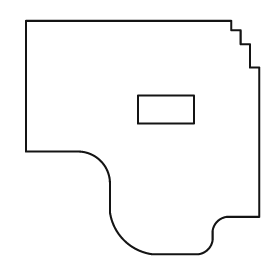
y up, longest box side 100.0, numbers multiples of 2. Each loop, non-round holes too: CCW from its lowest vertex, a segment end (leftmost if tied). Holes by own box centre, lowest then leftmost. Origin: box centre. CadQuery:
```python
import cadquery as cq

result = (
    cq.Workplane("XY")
    .moveTo(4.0, -50.0)
    .lineTo(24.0, -50.0)
    .threePointArc((28.0, -48.0), (30.0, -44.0))
    .lineTo(30.0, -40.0)
    .threePointArc((32.0, -36.0), (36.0, -34.0))
    .lineTo(50.0, -34.0)
    .lineTo(50.0, 30.0)
    .lineTo(46.0, 30.0)
    .lineTo(46.0, 40.0)
    .lineTo(42.0, 40.0)
    .lineTo(42.0, 46.0)
    .lineTo(38.0, 46.0)
    .lineTo(38.0, 50.0)
    .lineTo(-50.0, 50.0)
    .lineTo(-50.0, -6.0)
    .lineTo(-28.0, -6.0)
    .threePointArc((-18.0, -10.0), (-14.0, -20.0))
    .lineTo(-14.0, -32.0)
    .threePointArc((-8.0, -44.0), (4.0, -50.0))
    .close()
    .moveTo(-2.0, 6.0)
    .lineTo(22.0, 6.0)
    .lineTo(22.0, 18.0)
    .lineTo(-2.0, 18.0)
    .close()
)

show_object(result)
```